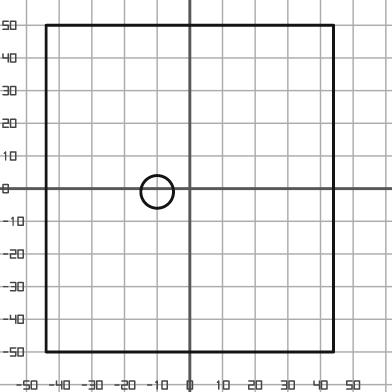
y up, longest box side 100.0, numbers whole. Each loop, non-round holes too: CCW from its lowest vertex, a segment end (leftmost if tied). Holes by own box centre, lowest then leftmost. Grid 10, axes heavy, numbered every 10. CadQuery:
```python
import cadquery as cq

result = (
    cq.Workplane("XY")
    .moveTo(-44.0, -50.0)
    .lineTo(44.0, -50.0)
    .lineTo(44.0, 50.0)
    .lineTo(-44.0, 50.0)
    .close()
    .moveTo(-10.0, -1.0)
    .circle(5.0)
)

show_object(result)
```